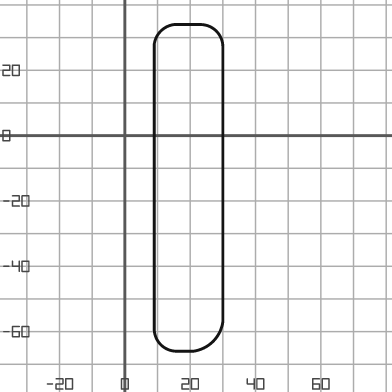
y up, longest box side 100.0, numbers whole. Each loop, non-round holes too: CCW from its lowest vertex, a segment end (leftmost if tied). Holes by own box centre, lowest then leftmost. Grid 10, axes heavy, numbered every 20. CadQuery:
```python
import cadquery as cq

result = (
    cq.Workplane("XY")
    .moveTo(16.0, -66.0)
    .lineTo(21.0, -66.0)
    .threePointArc((27.0, -63.0), (30.0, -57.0))
    .lineTo(30.0, 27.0)
    .threePointArc((28.0, 32.0), (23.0, 34.0))
    .lineTo(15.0, 34.0)
    .threePointArc((11.0, 32.0), (9.0, 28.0))
    .lineTo(9.0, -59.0)
    .threePointArc((11.0, -64.0), (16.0, -66.0))
    .close()
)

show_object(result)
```